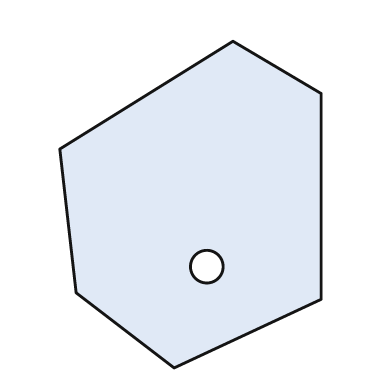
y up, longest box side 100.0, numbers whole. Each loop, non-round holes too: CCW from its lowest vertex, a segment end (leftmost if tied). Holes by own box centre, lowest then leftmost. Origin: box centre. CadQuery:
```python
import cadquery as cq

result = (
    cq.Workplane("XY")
    .moveTo(-5.0, -50.0)
    .lineTo(40.0, -29.0)
    .lineTo(40.0, 34.0)
    .lineTo(13.0, 50.0)
    .lineTo(-40.0, 17.0)
    .lineTo(-35.0, -27.0)
    .close()
    .moveTo(5.0, -19.0)
    .circle(5.0)
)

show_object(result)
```